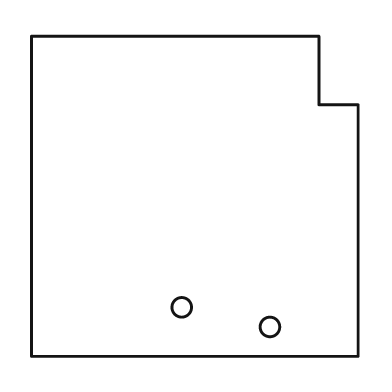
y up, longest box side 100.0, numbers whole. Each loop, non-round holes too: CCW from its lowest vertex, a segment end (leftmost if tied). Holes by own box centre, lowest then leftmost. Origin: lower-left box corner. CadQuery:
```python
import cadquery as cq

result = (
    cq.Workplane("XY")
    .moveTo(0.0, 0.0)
    .lineTo(100.0, 0.0)
    .lineTo(100.0, 77.0)
    .lineTo(88.0, 77.0)
    .lineTo(88.0, 98.0)
    .lineTo(0.0, 98.0)
    .close()
    .moveTo(73.0, 9.0)
    .circle(3.0)
    .moveTo(46.0, 15.0)
    .circle(3.0)
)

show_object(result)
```